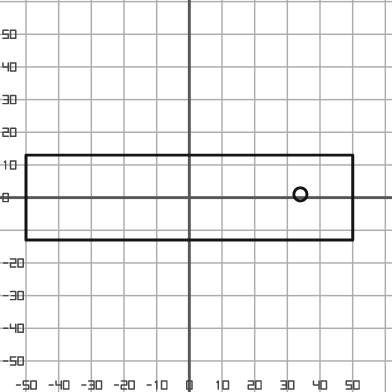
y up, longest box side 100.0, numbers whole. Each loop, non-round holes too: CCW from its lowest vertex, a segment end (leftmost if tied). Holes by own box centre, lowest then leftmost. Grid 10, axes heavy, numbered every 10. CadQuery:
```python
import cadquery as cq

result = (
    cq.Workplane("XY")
    .moveTo(-50.0, -13.0)
    .lineTo(50.0, -13.0)
    .lineTo(50.0, 13.0)
    .lineTo(-50.0, 13.0)
    .close()
    .moveTo(34.0, 1.0)
    .circle(2.0)
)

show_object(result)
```